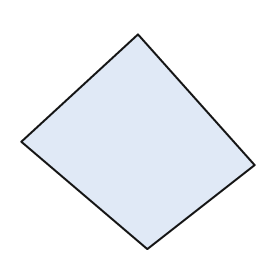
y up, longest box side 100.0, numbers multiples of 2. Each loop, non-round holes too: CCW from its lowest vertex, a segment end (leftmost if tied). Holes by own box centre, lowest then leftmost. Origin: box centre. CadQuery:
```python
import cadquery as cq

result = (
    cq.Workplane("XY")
    .moveTo(4.0, -46.0)
    .lineTo(50.0, -10.0)
    .lineTo(0.0, 46.0)
    .lineTo(-50.0, 0.0)
    .close()
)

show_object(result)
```